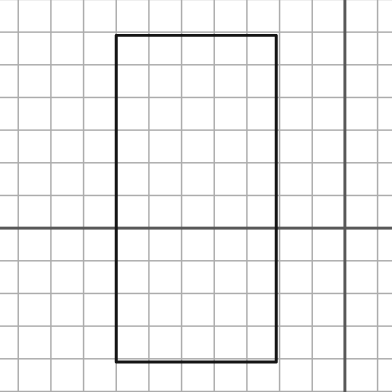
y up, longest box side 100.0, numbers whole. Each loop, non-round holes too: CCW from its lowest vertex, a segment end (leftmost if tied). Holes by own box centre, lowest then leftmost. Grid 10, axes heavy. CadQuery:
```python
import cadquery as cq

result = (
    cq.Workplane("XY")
    .moveTo(-70.0, -41.0)
    .lineTo(-21.0, -41.0)
    .lineTo(-21.0, 59.0)
    .lineTo(-70.0, 59.0)
    .close()
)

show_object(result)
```